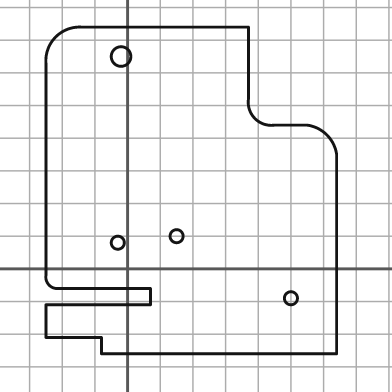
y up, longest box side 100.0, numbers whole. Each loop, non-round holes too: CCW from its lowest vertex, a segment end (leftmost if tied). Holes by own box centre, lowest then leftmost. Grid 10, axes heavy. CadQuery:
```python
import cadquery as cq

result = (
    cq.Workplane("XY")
    .moveTo(-8.0, -26.0)
    .lineTo(64.0, -26.0)
    .lineTo(64.0, 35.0)
    .threePointArc((61.0, 41.0), (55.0, 44.0))
    .lineTo(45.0, 44.0)
    .threePointArc((39.0, 46.0), (37.0, 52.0))
    .lineTo(37.0, 74.0)
    .lineTo(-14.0, 74.0)
    .threePointArc((-22.0, 71.0), (-25.0, 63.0))
    .lineTo(-25.0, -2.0)
    .threePointArc((-24.0, -5.0), (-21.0, -6.0))
    .lineTo(7.0, -6.0)
    .lineTo(7.0, -11.0)
    .lineTo(-25.0, -11.0)
    .lineTo(-25.0, -21.0)
    .lineTo(-8.0, -21.0)
    .close()
    .moveTo(50.0, -9.0)
    .circle(2.0)
    .moveTo(-3.0, 8.0)
    .circle(2.0)
    .moveTo(15.0, 10.0)
    .circle(2.0)
    .moveTo(-2.0, 65.0)
    .circle(3.0)
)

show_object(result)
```